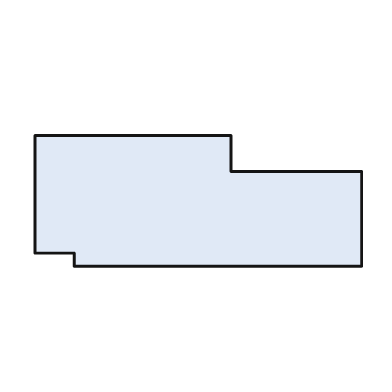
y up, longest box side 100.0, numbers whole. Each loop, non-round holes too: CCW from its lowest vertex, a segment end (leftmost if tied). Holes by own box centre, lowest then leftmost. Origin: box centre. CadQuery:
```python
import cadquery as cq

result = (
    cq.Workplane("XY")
    .moveTo(-38.0, -20.0)
    .lineTo(50.0, -20.0)
    .lineTo(50.0, 9.0)
    .lineTo(10.0, 9.0)
    .lineTo(10.0, 20.0)
    .lineTo(-50.0, 20.0)
    .lineTo(-50.0, -16.0)
    .lineTo(-38.0, -16.0)
    .close()
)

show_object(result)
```